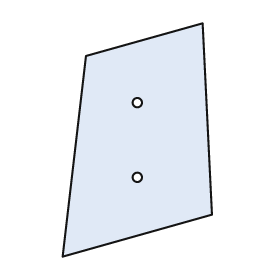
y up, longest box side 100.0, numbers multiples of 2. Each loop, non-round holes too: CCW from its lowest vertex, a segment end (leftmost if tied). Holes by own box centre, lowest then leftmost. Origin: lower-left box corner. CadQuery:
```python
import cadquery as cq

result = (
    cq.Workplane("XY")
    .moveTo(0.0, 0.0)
    .lineTo(64.0, 18.0)
    .lineTo(60.0, 100.0)
    .lineTo(10.0, 86.0)
    .close()
    .moveTo(32.0, 34.0)
    .circle(2.0)
    .moveTo(32.0, 66.0)
    .circle(2.0)
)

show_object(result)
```